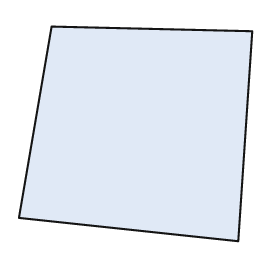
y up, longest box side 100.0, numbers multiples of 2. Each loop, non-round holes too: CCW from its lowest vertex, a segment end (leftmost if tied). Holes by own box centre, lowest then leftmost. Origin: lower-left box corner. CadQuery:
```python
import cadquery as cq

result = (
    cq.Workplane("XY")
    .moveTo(94.0, 0.0)
    .lineTo(100.0, 90.0)
    .lineTo(14.0, 92.0)
    .lineTo(0.0, 10.0)
    .close()
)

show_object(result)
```